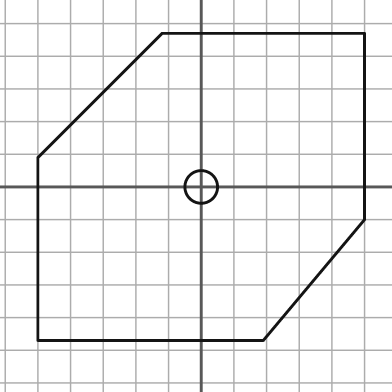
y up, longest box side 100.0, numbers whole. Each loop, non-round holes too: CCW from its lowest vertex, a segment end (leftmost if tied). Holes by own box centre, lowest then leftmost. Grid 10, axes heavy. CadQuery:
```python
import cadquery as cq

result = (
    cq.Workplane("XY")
    .moveTo(-50.0, -47.0)
    .lineTo(19.0, -47.0)
    .lineTo(50.0, -10.0)
    .lineTo(50.0, 47.0)
    .lineTo(-12.0, 47.0)
    .lineTo(-50.0, 9.0)
    .close()
    .moveTo(0.0, 0.0)
    .circle(5.0)
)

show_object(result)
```